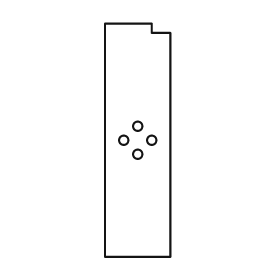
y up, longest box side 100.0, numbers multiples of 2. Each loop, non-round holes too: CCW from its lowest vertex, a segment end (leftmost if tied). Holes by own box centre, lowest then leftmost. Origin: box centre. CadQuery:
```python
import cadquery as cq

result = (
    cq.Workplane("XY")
    .moveTo(-14.0, -50.0)
    .lineTo(14.0, -50.0)
    .lineTo(14.0, 46.0)
    .lineTo(6.0, 46.0)
    .lineTo(6.0, 50.0)
    .lineTo(-14.0, 50.0)
    .close()
    .moveTo(0.0, -6.0)
    .circle(2.0)
    .moveTo(-6.0, 0.0)
    .circle(2.0)
    .moveTo(6.0, 0.0)
    .circle(2.0)
    .moveTo(0.0, 6.0)
    .circle(2.0)
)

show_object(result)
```